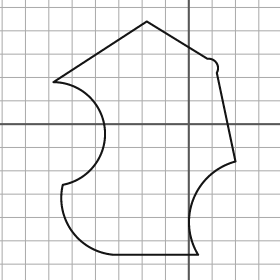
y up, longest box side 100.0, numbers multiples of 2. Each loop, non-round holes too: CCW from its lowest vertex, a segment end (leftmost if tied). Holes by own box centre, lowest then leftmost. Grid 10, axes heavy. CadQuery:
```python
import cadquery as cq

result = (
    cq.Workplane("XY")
    .moveTo(-32.0, -56.0)
    .lineTo(4.0, -56.0)
    .threePointArc((2.0, -32.0), (20.0, -16.0))
    .lineTo(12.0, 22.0)
    .threePointArc((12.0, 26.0), (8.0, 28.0))
    .lineTo(-18.0, 44.0)
    .lineTo(-58.0, 18.0)
    .threePointArc((-36.0, -2.0), (-54.0, -26.0))
    .threePointArc((-50.0, -46.0), (-32.0, -56.0))
    .close()
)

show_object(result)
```